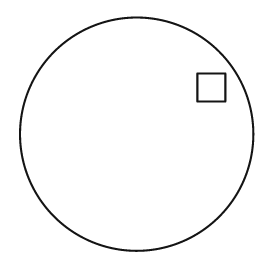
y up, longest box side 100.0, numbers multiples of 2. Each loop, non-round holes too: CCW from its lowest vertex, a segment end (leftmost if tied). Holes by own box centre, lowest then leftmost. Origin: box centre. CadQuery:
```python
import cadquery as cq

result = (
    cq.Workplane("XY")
    .moveTo(0.0, 0.0)
    .circle(50.0)
    .moveTo(26.0, 14.0)
    .lineTo(38.0, 14.0)
    .lineTo(38.0, 26.0)
    .lineTo(26.0, 26.0)
    .close()
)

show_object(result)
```